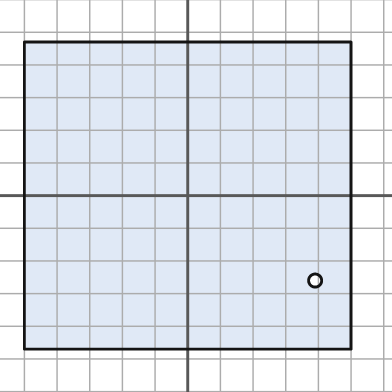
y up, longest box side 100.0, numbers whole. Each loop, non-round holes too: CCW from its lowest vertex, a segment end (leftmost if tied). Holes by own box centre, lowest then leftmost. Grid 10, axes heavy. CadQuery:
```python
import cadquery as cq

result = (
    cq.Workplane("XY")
    .moveTo(-50.0, -47.0)
    .lineTo(50.0, -47.0)
    .lineTo(50.0, 47.0)
    .lineTo(-50.0, 47.0)
    .close()
    .moveTo(39.0, -26.0)
    .circle(2.0)
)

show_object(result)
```